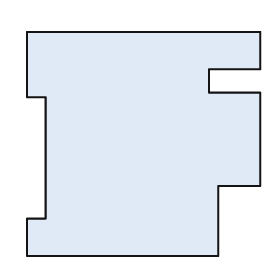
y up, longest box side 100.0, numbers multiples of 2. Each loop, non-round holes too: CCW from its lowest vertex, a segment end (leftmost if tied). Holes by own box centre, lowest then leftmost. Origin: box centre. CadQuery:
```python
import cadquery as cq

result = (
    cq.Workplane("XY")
    .moveTo(-50.0, -48.0)
    .lineTo(32.0, -48.0)
    .lineTo(32.0, -18.0)
    .lineTo(50.0, -18.0)
    .lineTo(50.0, 22.0)
    .lineTo(28.0, 22.0)
    .lineTo(28.0, 32.0)
    .lineTo(50.0, 32.0)
    .lineTo(50.0, 48.0)
    .lineTo(-50.0, 48.0)
    .lineTo(-50.0, 20.0)
    .lineTo(-42.0, 20.0)
    .lineTo(-42.0, -32.0)
    .lineTo(-50.0, -32.0)
    .close()
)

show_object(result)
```